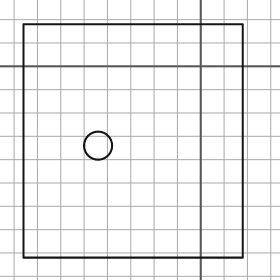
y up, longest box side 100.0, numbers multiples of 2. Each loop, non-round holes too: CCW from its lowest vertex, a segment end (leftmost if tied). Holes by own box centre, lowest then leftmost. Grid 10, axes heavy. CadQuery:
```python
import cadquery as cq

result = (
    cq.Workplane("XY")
    .moveTo(-76.0, -82.0)
    .lineTo(18.0, -82.0)
    .lineTo(18.0, 18.0)
    .lineTo(-76.0, 18.0)
    .close()
    .moveTo(-44.0, -34.0)
    .circle(6.0)
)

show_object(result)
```